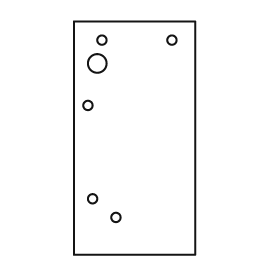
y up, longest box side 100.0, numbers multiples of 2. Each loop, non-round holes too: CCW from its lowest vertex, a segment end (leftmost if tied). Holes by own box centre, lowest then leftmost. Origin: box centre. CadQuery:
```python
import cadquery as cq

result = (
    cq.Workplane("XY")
    .moveTo(-26.0, -50.0)
    .lineTo(26.0, -50.0)
    .lineTo(26.0, 50.0)
    .lineTo(-26.0, 50.0)
    .close()
    .moveTo(-8.0, -34.0)
    .circle(2.0)
    .moveTo(-18.0, -26.0)
    .circle(2.0)
    .moveTo(-20.0, 14.0)
    .circle(2.0)
    .moveTo(-16.0, 32.0)
    .circle(4.0)
    .moveTo(-14.0, 42.0)
    .circle(2.0)
    .moveTo(16.0, 42.0)
    .circle(2.0)
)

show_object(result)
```